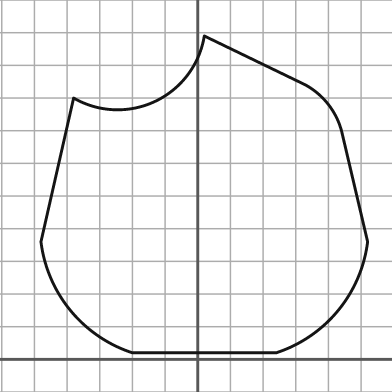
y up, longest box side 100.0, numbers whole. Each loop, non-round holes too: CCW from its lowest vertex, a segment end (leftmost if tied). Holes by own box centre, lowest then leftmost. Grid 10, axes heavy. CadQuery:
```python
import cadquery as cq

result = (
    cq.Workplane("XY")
    .moveTo(-20.0, 2.0)
    .lineTo(24.0, 2.0)
    .threePointArc((43.0, 15.0), (52.0, 36.0))
    .lineTo(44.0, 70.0)
    .threePointArc((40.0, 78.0), (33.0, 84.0))
    .lineTo(2.0, 99.0)
    .threePointArc((-13.0, 79.0), (-38.0, 80.0))
    .lineTo(-48.0, 36.0)
    .threePointArc((-39.0, 15.0), (-20.0, 2.0))
    .close()
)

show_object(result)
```